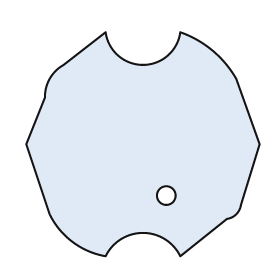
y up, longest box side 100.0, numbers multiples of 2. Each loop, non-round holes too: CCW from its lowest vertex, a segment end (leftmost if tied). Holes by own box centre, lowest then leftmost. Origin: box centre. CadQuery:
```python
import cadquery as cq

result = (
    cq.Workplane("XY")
    .moveTo(-16.0, -48.0)
    .threePointArc((0.0, -38.0), (16.0, -48.0))
    .lineTo(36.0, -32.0)
    .threePointArc((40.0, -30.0), (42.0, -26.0))
    .lineTo(50.0, 0.0)
    .lineTo(40.0, 28.0)
    .threePointArc((30.0, 40.0), (16.0, 48.0))
    .threePointArc((0.0, 34.0), (-16.0, 48.0))
    .lineTo(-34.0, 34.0)
    .threePointArc((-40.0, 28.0), (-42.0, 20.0))
    .lineTo(-50.0, 0.0)
    .lineTo(-40.0, -30.0)
    .threePointArc((-30.0, -42.0), (-16.0, -48.0))
    .close()
    .moveTo(10.0, -22.0)
    .circle(4.0)
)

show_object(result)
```